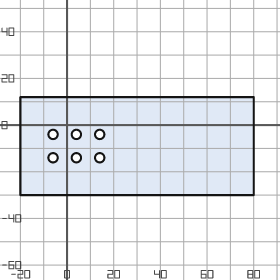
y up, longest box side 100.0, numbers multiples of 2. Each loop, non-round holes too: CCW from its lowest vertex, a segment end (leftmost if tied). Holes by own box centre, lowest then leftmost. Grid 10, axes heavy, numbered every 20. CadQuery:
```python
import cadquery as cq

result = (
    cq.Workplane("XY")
    .moveTo(-20.0, -30.0)
    .lineTo(80.0, -30.0)
    .lineTo(80.0, 12.0)
    .lineTo(-20.0, 12.0)
    .close()
    .moveTo(-6.0, -14.0)
    .circle(2.0)
    .moveTo(4.0, -14.0)
    .circle(2.0)
    .moveTo(14.0, -14.0)
    .circle(2.0)
    .moveTo(-6.0, -4.0)
    .circle(2.0)
    .moveTo(4.0, -4.0)
    .circle(2.0)
    .moveTo(14.0, -4.0)
    .circle(2.0)
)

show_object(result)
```